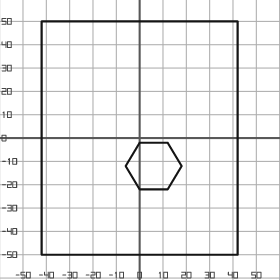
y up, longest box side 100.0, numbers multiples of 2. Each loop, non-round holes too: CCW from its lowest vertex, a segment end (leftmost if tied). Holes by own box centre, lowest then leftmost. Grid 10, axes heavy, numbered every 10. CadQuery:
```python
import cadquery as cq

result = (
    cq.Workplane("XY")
    .moveTo(-42.0, -50.0)
    .lineTo(42.0, -50.0)
    .lineTo(42.0, 50.0)
    .lineTo(-42.0, 50.0)
    .close()
    .moveTo(0.0, -22.0)
    .lineTo(12.0, -22.0)
    .lineTo(18.0, -12.0)
    .lineTo(12.0, -2.0)
    .lineTo(0.0, -2.0)
    .lineTo(-6.0, -12.0)
    .close()
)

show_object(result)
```